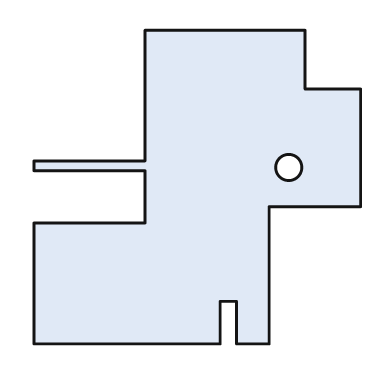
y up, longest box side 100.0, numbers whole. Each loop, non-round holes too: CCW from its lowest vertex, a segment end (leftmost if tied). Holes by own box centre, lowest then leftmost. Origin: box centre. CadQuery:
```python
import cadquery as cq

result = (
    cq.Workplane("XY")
    .moveTo(-50.0, -48.0)
    .lineTo(7.0, -48.0)
    .lineTo(7.0, -35.0)
    .lineTo(12.0, -35.0)
    .lineTo(12.0, -48.0)
    .lineTo(22.0, -48.0)
    .lineTo(22.0, -6.0)
    .lineTo(50.0, -6.0)
    .lineTo(50.0, 30.0)
    .lineTo(33.0, 30.0)
    .lineTo(33.0, 48.0)
    .lineTo(-16.0, 48.0)
    .lineTo(-16.0, 8.0)
    .lineTo(-50.0, 8.0)
    .lineTo(-50.0, 5.0)
    .lineTo(-16.0, 5.0)
    .lineTo(-16.0, -11.0)
    .lineTo(-50.0, -11.0)
    .close()
    .moveTo(28.0, 6.0)
    .circle(4.0)
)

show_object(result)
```